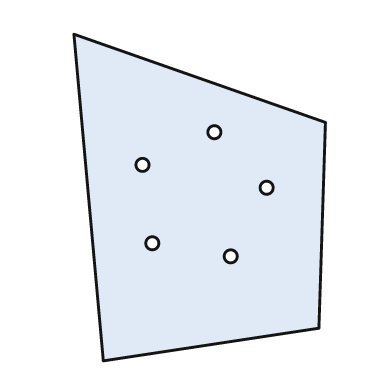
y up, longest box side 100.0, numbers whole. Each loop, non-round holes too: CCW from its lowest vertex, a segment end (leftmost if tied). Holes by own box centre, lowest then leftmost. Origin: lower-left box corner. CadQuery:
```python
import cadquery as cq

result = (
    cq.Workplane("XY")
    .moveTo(9.0, 0.0)
    .lineTo(75.0, 10.0)
    .lineTo(77.0, 73.0)
    .lineTo(0.0, 100.0)
    .close()
    .moveTo(48.0, 32.0)
    .circle(2.0)
    .moveTo(24.0, 36.0)
    .circle(2.0)
    .moveTo(59.0, 53.0)
    .circle(2.0)
    .moveTo(21.0, 60.0)
    .circle(2.0)
    .moveTo(43.0, 70.0)
    .circle(2.0)
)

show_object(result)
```